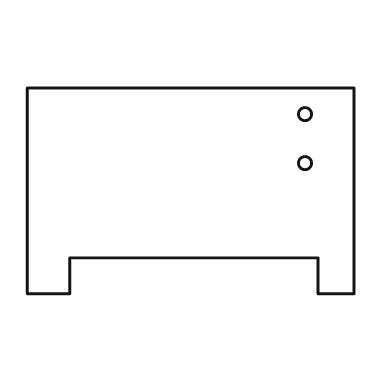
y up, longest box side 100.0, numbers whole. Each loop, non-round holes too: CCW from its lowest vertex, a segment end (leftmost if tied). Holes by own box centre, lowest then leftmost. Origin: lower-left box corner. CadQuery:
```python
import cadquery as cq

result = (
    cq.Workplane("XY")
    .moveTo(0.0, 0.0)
    .lineTo(13.0, 0.0)
    .lineTo(13.0, 11.0)
    .lineTo(89.0, 11.0)
    .lineTo(89.0, 0.0)
    .lineTo(100.0, 0.0)
    .lineTo(100.0, 63.0)
    .lineTo(0.0, 63.0)
    .close()
    .moveTo(85.0, 40.0)
    .circle(2.0)
    .moveTo(85.0, 55.0)
    .circle(2.0)
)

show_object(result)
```